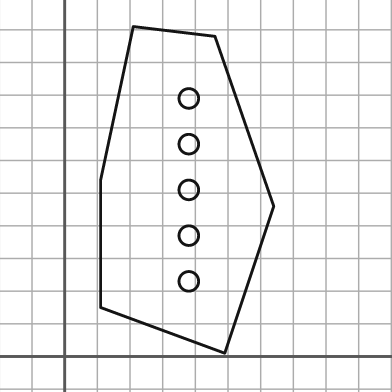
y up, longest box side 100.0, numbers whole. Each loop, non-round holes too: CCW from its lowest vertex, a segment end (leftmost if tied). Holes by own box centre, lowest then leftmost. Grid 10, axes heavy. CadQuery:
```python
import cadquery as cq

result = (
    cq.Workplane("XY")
    .moveTo(49.0, 1.0)
    .lineTo(64.0, 46.0)
    .lineTo(46.0, 98.0)
    .lineTo(21.0, 101.0)
    .lineTo(11.0, 54.0)
    .lineTo(11.0, 15.0)
    .close()
    .moveTo(38.0, 23.0)
    .circle(3.0)
    .moveTo(38.0, 37.0)
    .circle(3.0)
    .moveTo(38.0, 51.0)
    .circle(3.0)
    .moveTo(38.0, 65.0)
    .circle(3.0)
    .moveTo(38.0, 79.0)
    .circle(3.0)
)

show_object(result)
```